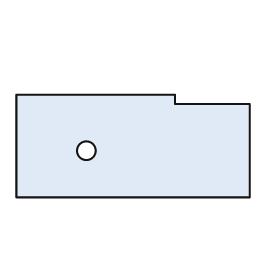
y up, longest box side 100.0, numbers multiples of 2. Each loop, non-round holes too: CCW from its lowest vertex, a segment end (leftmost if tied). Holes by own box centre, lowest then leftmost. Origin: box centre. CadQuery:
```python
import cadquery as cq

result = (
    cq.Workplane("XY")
    .moveTo(-50.0, -22.0)
    .lineTo(50.0, -22.0)
    .lineTo(50.0, 18.0)
    .lineTo(18.0, 18.0)
    .lineTo(18.0, 22.0)
    .lineTo(-50.0, 22.0)
    .close()
    .moveTo(-20.0, -2.0)
    .circle(4.0)
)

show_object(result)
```